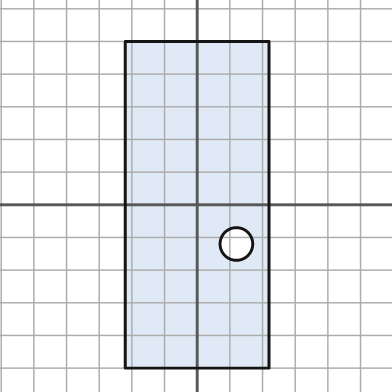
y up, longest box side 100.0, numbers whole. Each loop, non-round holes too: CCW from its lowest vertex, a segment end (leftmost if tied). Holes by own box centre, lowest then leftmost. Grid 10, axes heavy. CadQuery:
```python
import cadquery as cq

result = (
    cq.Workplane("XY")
    .moveTo(-22.0, -50.0)
    .lineTo(22.0, -50.0)
    .lineTo(22.0, 50.0)
    .lineTo(-22.0, 50.0)
    .close()
    .moveTo(12.0, -12.0)
    .circle(5.0)
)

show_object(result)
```